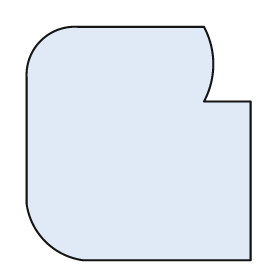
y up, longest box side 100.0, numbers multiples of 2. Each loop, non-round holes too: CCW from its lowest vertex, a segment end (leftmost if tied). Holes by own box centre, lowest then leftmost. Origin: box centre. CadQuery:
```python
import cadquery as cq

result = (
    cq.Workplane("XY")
    .moveTo(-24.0, -50.0)
    .lineTo(48.0, -50.0)
    .lineTo(48.0, 18.0)
    .lineTo(28.0, 18.0)
    .threePointArc((32.0, 34.0), (28.0, 50.0))
    .lineTo(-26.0, 50.0)
    .threePointArc((-42.0, 44.0), (-48.0, 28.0))
    .lineTo(-48.0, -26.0)
    .threePointArc((-40.0, -42.0), (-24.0, -50.0))
    .close()
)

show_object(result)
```